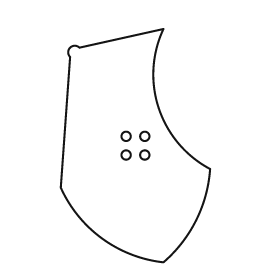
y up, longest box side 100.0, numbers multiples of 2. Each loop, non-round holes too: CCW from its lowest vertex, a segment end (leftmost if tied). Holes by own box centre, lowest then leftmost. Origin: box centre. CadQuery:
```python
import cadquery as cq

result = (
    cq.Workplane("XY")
    .moveTo(12.0, -50.0)
    .threePointArc((26.0, -32.0), (32.0, -10.0))
    .threePointArc((10.0, 16.0), (12.0, 50.0))
    .lineTo(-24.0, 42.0)
    .threePointArc((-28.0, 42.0), (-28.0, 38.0))
    .lineTo(-32.0, -18.0)
    .threePointArc((-14.0, -40.0), (12.0, -50.0))
    .close()
    .moveTo(-4.0, -4.0)
    .circle(2.0)
    .moveTo(4.0, -4.0)
    .circle(2.0)
    .moveTo(-4.0, 4.0)
    .circle(2.0)
    .moveTo(4.0, 4.0)
    .circle(2.0)
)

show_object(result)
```